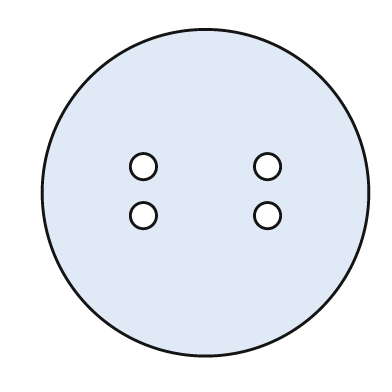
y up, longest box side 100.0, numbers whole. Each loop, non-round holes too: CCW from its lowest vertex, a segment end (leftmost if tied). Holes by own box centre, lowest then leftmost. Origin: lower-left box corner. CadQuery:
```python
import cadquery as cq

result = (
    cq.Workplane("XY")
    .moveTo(50.0, 50.0)
    .circle(50.0)
    .moveTo(31.0, 43.0)
    .circle(4.0)
    .moveTo(69.0, 43.0)
    .circle(4.0)
    .moveTo(31.0, 58.0)
    .circle(4.0)
    .moveTo(69.0, 58.0)
    .circle(4.0)
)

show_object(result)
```